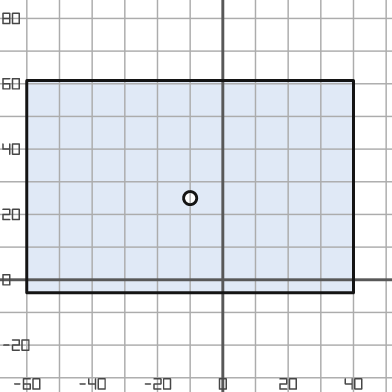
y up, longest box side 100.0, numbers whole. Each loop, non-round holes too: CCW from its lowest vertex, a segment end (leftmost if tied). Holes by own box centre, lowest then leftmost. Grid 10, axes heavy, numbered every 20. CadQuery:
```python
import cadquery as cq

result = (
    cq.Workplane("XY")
    .moveTo(-60.0, -4.0)
    .lineTo(40.0, -4.0)
    .lineTo(40.0, 61.0)
    .lineTo(-60.0, 61.0)
    .close()
    .moveTo(-10.0, 25.0)
    .circle(2.0)
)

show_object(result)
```